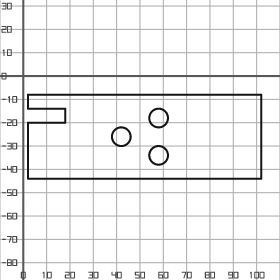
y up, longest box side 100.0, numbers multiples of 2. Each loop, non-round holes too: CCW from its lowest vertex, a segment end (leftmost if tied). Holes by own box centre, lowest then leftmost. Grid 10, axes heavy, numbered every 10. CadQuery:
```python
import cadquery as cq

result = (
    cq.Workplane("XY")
    .moveTo(2.0, -44.0)
    .lineTo(102.0, -44.0)
    .lineTo(102.0, -8.0)
    .lineTo(2.0, -8.0)
    .lineTo(2.0, -14.0)
    .lineTo(18.0, -14.0)
    .lineTo(18.0, -20.0)
    .lineTo(2.0, -20.0)
    .close()
    .moveTo(58.0, -34.0)
    .circle(4.0)
    .moveTo(42.0, -26.0)
    .circle(4.0)
    .moveTo(58.0, -18.0)
    .circle(4.0)
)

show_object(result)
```